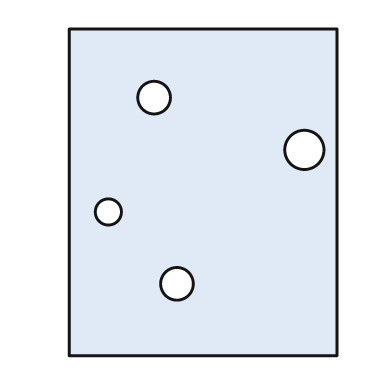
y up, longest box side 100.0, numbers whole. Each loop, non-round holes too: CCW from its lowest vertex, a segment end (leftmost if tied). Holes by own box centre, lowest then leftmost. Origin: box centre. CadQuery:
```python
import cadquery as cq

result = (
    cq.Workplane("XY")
    .moveTo(-41.0, -50.0)
    .lineTo(41.0, -50.0)
    .lineTo(41.0, 50.0)
    .lineTo(-41.0, 50.0)
    .close()
    .moveTo(-8.0, -28.0)
    .circle(5.0)
    .moveTo(-29.0, -6.0)
    .circle(4.0)
    .moveTo(31.0, 13.0)
    .circle(6.0)
    .moveTo(-15.0, 29.0)
    .circle(5.0)
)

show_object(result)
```